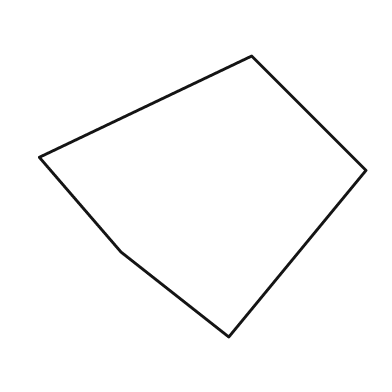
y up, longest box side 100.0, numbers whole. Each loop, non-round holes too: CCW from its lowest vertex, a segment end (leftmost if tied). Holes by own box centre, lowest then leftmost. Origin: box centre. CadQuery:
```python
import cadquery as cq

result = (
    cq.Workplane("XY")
    .moveTo(8.0, -43.0)
    .lineTo(50.0, 8.0)
    .lineTo(15.0, 43.0)
    .lineTo(-50.0, 12.0)
    .lineTo(-25.0, -17.0)
    .close()
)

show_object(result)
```